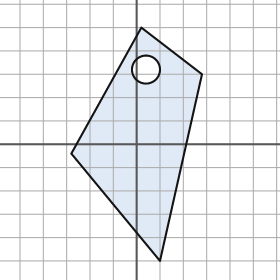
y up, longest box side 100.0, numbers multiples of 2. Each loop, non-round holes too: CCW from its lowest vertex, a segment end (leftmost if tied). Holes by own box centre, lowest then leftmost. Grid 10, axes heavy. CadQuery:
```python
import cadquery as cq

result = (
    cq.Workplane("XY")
    .moveTo(10.0, -50.0)
    .lineTo(28.0, 30.0)
    .lineTo(2.0, 50.0)
    .lineTo(-28.0, -4.0)
    .close()
    .moveTo(4.0, 32.0)
    .circle(6.0)
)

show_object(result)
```